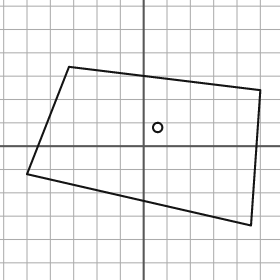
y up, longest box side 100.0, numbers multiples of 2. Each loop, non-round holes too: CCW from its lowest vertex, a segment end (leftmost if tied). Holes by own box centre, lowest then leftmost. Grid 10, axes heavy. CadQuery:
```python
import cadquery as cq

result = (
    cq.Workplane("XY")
    .moveTo(46.0, -34.0)
    .lineTo(50.0, 24.0)
    .lineTo(-32.0, 34.0)
    .lineTo(-50.0, -12.0)
    .close()
    .moveTo(6.0, 8.0)
    .circle(2.0)
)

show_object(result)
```